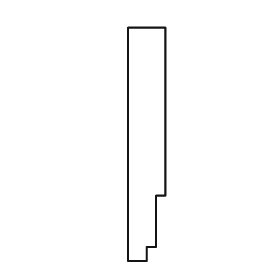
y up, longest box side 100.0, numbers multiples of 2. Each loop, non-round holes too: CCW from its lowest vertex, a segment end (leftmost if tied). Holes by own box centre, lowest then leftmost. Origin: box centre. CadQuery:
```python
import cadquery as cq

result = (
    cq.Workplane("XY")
    .moveTo(-8.0, -50.0)
    .lineTo(0.0, -50.0)
    .lineTo(0.0, -44.0)
    .lineTo(4.0, -44.0)
    .lineTo(4.0, -22.0)
    .lineTo(8.0, -22.0)
    .lineTo(8.0, 50.0)
    .lineTo(-8.0, 50.0)
    .close()
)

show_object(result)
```